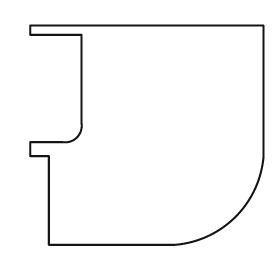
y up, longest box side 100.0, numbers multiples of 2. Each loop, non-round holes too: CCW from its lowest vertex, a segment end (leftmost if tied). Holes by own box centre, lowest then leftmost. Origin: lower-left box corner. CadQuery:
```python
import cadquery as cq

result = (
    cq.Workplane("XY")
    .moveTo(8.0, 0.0)
    .lineTo(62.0, 0.0)
    .threePointArc((88.0, 12.0), (100.0, 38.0))
    .lineTo(100.0, 94.0)
    .lineTo(0.0, 94.0)
    .lineTo(0.0, 90.0)
    .lineTo(22.0, 90.0)
    .lineTo(22.0, 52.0)
    .threePointArc((20.0, 46.0), (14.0, 44.0))
    .lineTo(0.0, 44.0)
    .lineTo(0.0, 38.0)
    .lineTo(8.0, 38.0)
    .close()
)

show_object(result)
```